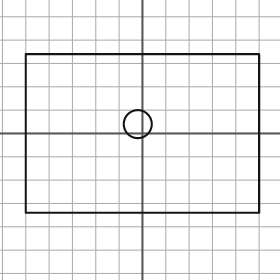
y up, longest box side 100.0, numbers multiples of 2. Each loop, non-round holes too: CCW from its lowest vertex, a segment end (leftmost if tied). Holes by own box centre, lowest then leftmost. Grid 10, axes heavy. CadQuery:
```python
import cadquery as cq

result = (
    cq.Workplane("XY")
    .moveTo(-50.0, -34.0)
    .lineTo(50.0, -34.0)
    .lineTo(50.0, 34.0)
    .lineTo(-50.0, 34.0)
    .close()
    .moveTo(-2.0, 4.0)
    .circle(6.0)
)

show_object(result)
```